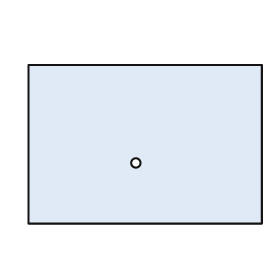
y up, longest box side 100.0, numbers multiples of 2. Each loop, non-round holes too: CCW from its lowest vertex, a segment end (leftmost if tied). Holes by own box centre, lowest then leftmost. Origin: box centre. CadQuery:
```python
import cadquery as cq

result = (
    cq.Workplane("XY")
    .moveTo(-50.0, -34.0)
    .lineTo(50.0, -34.0)
    .lineTo(50.0, 34.0)
    .lineTo(-50.0, 34.0)
    .close()
    .moveTo(-4.0, -8.0)
    .circle(2.0)
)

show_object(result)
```